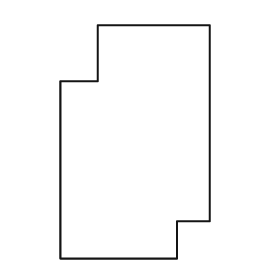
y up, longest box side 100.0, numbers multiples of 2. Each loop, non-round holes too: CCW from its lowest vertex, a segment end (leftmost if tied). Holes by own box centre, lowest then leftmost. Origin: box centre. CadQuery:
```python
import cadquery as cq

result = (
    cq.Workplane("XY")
    .moveTo(-32.0, -50.0)
    .lineTo(18.0, -50.0)
    .lineTo(18.0, -34.0)
    .lineTo(32.0, -34.0)
    .lineTo(32.0, 50.0)
    .lineTo(-16.0, 50.0)
    .lineTo(-16.0, 26.0)
    .lineTo(-32.0, 26.0)
    .close()
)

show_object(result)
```